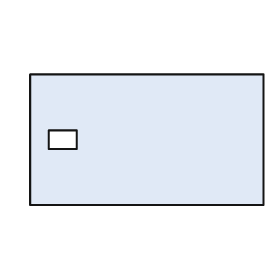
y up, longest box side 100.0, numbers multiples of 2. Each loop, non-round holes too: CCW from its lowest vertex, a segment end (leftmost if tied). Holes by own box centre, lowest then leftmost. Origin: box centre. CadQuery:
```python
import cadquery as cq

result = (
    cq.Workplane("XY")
    .moveTo(-50.0, -28.0)
    .lineTo(50.0, -28.0)
    .lineTo(50.0, 28.0)
    .lineTo(-50.0, 28.0)
    .close()
    .moveTo(-42.0, -4.0)
    .lineTo(-30.0, -4.0)
    .lineTo(-30.0, 4.0)
    .lineTo(-42.0, 4.0)
    .close()
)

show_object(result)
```